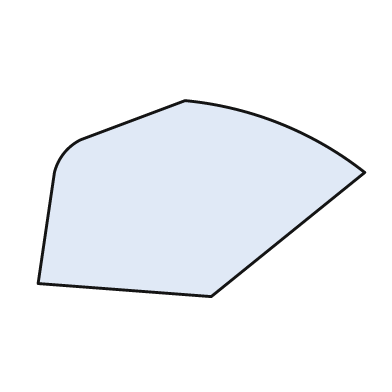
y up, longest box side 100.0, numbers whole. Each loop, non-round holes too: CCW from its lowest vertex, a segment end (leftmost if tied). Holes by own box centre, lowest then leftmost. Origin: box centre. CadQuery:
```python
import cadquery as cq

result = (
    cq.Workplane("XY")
    .moveTo(3.0, -30.0)
    .lineTo(50.0, 8.0)
    .threePointArc((24.0, 23.0), (-5.0, 30.0))
    .lineTo(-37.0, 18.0)
    .threePointArc((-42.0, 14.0), (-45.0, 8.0))
    .lineTo(-50.0, -26.0)
    .close()
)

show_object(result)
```